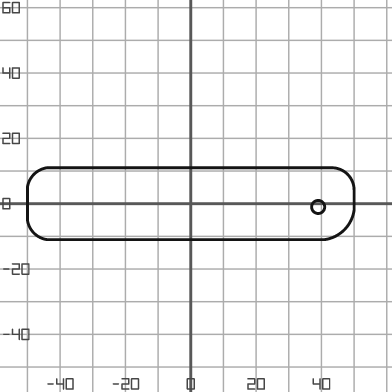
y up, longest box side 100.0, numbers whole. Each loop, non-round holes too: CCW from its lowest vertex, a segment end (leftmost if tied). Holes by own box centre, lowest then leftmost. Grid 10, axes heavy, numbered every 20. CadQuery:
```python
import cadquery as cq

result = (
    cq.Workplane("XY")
    .moveTo(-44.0, -11.0)
    .lineTo(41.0, -11.0)
    .threePointArc((47.0, -8.0), (50.0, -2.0))
    .lineTo(50.0, 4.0)
    .threePointArc((48.0, 9.0), (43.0, 11.0))
    .lineTo(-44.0, 11.0)
    .threePointArc((-48.0, 9.0), (-50.0, 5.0))
    .lineTo(-50.0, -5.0)
    .threePointArc((-48.0, -9.0), (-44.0, -11.0))
    .close()
    .moveTo(39.0, -1.0)
    .circle(2.0)
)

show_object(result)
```